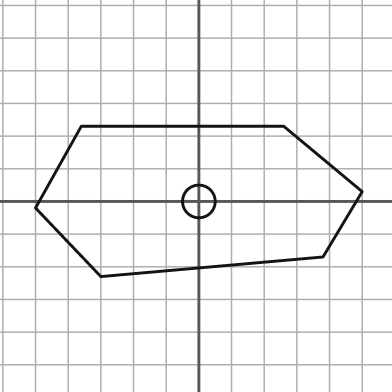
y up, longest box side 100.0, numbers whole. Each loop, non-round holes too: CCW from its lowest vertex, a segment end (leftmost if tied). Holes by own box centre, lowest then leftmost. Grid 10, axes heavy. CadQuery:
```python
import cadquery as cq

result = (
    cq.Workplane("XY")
    .moveTo(-30.0, -23.0)
    .lineTo(38.0, -17.0)
    .lineTo(50.0, 3.0)
    .lineTo(26.0, 23.0)
    .lineTo(-36.0, 23.0)
    .lineTo(-50.0, -2.0)
    .close()
    .moveTo(0.0, 0.0)
    .circle(5.0)
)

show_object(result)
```